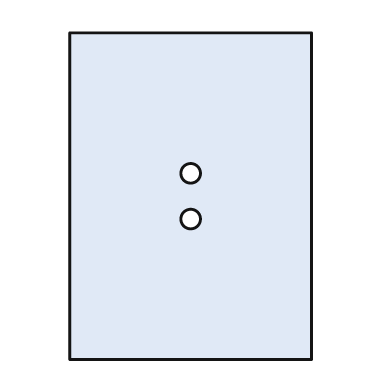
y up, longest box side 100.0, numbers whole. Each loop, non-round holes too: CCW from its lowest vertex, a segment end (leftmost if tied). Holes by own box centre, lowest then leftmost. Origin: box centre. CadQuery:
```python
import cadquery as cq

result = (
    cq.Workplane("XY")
    .moveTo(-37.0, -50.0)
    .lineTo(37.0, -50.0)
    .lineTo(37.0, 50.0)
    .lineTo(-37.0, 50.0)
    .close()
    .moveTo(0.0, -7.0)
    .circle(3.0)
    .moveTo(0.0, 7.0)
    .circle(3.0)
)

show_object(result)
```